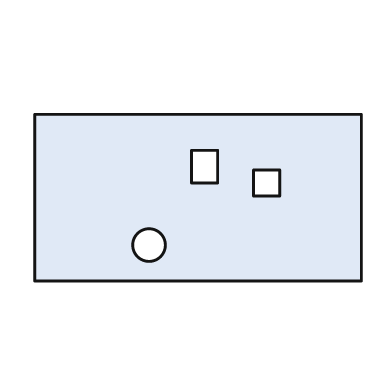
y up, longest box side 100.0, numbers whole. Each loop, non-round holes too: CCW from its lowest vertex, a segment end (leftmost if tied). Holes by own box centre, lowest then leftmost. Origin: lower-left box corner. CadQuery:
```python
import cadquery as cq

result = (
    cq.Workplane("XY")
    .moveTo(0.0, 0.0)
    .lineTo(100.0, 0.0)
    .lineTo(100.0, 51.0)
    .lineTo(0.0, 51.0)
    .close()
    .moveTo(35.0, 11.0)
    .circle(5.0)
    .moveTo(67.0, 26.0)
    .lineTo(75.0, 26.0)
    .lineTo(75.0, 34.0)
    .lineTo(67.0, 34.0)
    .close()
    .moveTo(48.0, 30.0)
    .lineTo(56.0, 30.0)
    .lineTo(56.0, 40.0)
    .lineTo(48.0, 40.0)
    .close()
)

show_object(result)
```